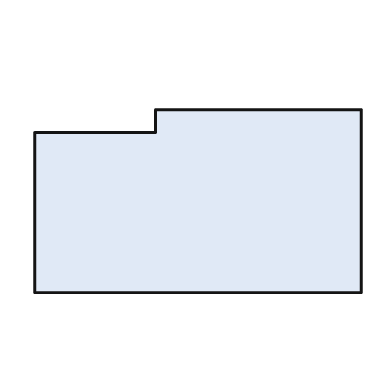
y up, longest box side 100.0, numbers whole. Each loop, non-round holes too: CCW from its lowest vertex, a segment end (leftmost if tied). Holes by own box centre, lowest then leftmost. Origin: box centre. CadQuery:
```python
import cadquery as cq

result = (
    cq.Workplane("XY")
    .moveTo(-50.0, -28.0)
    .lineTo(50.0, -28.0)
    .lineTo(50.0, 28.0)
    .lineTo(-13.0, 28.0)
    .lineTo(-13.0, 21.0)
    .lineTo(-50.0, 21.0)
    .close()
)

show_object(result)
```